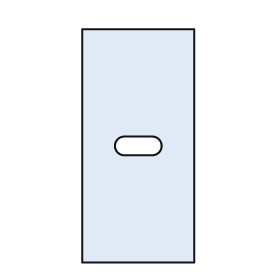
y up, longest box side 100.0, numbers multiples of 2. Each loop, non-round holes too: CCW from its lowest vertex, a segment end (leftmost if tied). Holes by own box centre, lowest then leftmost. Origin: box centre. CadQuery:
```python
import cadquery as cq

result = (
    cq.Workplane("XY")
    .moveTo(-24.0, -50.0)
    .lineTo(24.0, -50.0)
    .lineTo(24.0, 50.0)
    .lineTo(-24.0, 50.0)
    .close()
    .moveTo(-6.0, -4.0)
    .lineTo(6.0, -4.0)
    .threePointArc((10.0, 0.0), (6.0, 4.0))
    .lineTo(-6.0, 4.0)
    .threePointArc((-10.0, 0.0), (-6.0, -4.0))
    .close()
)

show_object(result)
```